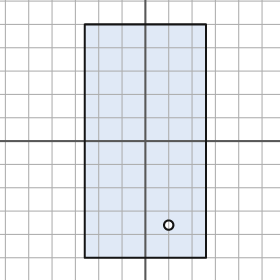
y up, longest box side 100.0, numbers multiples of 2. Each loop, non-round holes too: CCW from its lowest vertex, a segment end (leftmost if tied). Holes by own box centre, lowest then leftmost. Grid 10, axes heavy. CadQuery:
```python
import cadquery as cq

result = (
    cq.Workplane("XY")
    .moveTo(-26.0, -50.0)
    .lineTo(26.0, -50.0)
    .lineTo(26.0, 50.0)
    .lineTo(-26.0, 50.0)
    .close()
    .moveTo(10.0, -36.0)
    .circle(2.0)
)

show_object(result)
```